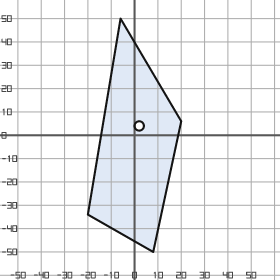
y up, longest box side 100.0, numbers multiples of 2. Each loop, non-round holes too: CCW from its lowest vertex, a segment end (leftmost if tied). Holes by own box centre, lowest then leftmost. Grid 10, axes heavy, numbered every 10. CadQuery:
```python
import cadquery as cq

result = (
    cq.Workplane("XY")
    .moveTo(8.0, -50.0)
    .lineTo(20.0, 6.0)
    .lineTo(-6.0, 50.0)
    .lineTo(-20.0, -34.0)
    .close()
    .moveTo(2.0, 4.0)
    .circle(2.0)
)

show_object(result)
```